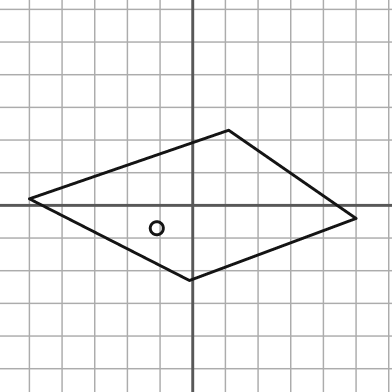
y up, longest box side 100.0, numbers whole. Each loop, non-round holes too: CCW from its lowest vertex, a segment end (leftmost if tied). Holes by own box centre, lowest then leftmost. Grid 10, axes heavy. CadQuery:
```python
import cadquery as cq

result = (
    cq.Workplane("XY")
    .moveTo(-1.0, -23.0)
    .lineTo(50.0, -4.0)
    .lineTo(11.0, 23.0)
    .lineTo(-50.0, 2.0)
    .close()
    .moveTo(-11.0, -7.0)
    .circle(2.0)
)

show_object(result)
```